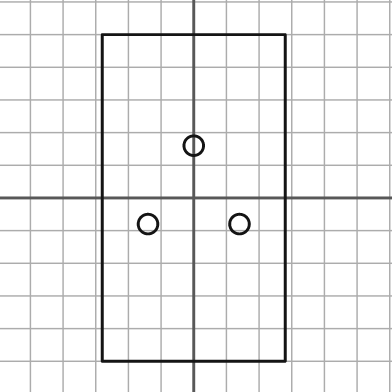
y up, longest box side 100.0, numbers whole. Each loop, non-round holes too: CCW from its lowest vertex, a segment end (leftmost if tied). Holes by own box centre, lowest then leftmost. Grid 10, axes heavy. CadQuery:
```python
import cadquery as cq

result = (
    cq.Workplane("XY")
    .moveTo(-28.0, -50.0)
    .lineTo(28.0, -50.0)
    .lineTo(28.0, 50.0)
    .lineTo(-28.0, 50.0)
    .close()
    .moveTo(-14.0, -8.0)
    .circle(3.0)
    .moveTo(14.0, -8.0)
    .circle(3.0)
    .moveTo(0.0, 16.0)
    .circle(3.0)
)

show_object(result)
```